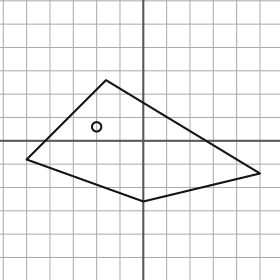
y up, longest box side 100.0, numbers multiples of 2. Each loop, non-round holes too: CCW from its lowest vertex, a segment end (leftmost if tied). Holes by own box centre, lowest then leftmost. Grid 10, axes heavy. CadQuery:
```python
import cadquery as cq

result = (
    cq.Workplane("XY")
    .moveTo(0.0, -26.0)
    .lineTo(50.0, -14.0)
    .lineTo(-16.0, 26.0)
    .lineTo(-50.0, -8.0)
    .close()
    .moveTo(-20.0, 6.0)
    .circle(2.0)
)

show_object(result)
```